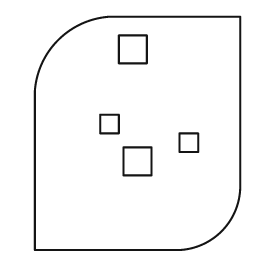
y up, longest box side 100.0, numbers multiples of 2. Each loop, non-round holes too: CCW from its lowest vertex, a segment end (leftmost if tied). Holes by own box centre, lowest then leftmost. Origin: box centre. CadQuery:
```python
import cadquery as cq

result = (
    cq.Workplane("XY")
    .moveTo(-44.0, -50.0)
    .lineTo(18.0, -50.0)
    .threePointArc((36.0, -42.0), (44.0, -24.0))
    .lineTo(44.0, 50.0)
    .lineTo(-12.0, 50.0)
    .threePointArc((-34.0, 40.0), (-44.0, 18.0))
    .close()
    .moveTo(-6.0, -18.0)
    .lineTo(6.0, -18.0)
    .lineTo(6.0, -6.0)
    .lineTo(-6.0, -6.0)
    .close()
    .moveTo(18.0, -8.0)
    .lineTo(26.0, -8.0)
    .lineTo(26.0, 0.0)
    .lineTo(18.0, 0.0)
    .close()
    .moveTo(-16.0, 0.0)
    .lineTo(-8.0, 0.0)
    .lineTo(-8.0, 8.0)
    .lineTo(-16.0, 8.0)
    .close()
    .moveTo(-8.0, 30.0)
    .lineTo(4.0, 30.0)
    .lineTo(4.0, 42.0)
    .lineTo(-8.0, 42.0)
    .close()
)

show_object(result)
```